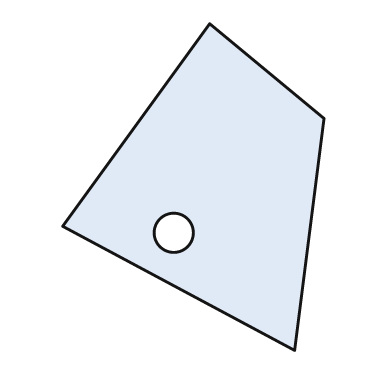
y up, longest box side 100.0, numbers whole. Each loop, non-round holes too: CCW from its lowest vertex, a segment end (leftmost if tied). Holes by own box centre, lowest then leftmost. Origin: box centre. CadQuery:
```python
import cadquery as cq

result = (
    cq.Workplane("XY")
    .moveTo(31.0, -50.0)
    .lineTo(40.0, 21.0)
    .lineTo(5.0, 50.0)
    .lineTo(-40.0, -12.0)
    .close()
    .moveTo(-6.0, -14.0)
    .circle(6.0)
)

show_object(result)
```